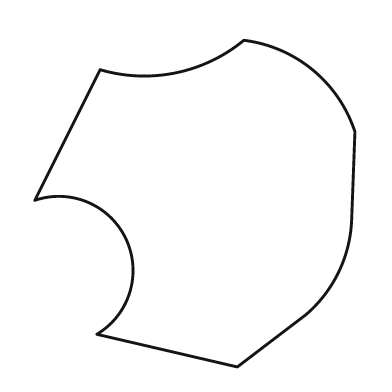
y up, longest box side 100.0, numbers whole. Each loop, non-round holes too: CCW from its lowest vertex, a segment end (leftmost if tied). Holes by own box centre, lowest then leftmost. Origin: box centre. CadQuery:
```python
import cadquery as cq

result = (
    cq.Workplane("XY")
    .moveTo(13.0, -50.0)
    .lineTo(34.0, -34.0)
    .threePointArc((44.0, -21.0), (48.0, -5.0))
    .lineTo(49.0, 22.0)
    .threePointArc((36.0, 41.0), (15.0, 50.0))
    .threePointArc((-6.0, 40.0), (-29.0, 41.0))
    .lineTo(-49.0, 1.0)
    .threePointArc((-21.0, -11.0), (-30.0, -40.0))
    .close()
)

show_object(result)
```